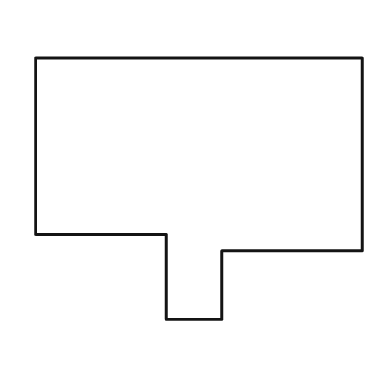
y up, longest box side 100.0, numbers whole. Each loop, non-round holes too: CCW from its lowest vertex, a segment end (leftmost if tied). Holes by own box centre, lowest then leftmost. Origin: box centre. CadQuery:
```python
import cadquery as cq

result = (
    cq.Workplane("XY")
    .moveTo(-10.0, -40.0)
    .lineTo(7.0, -40.0)
    .lineTo(7.0, -19.0)
    .lineTo(50.0, -19.0)
    .lineTo(50.0, 40.0)
    .lineTo(-50.0, 40.0)
    .lineTo(-50.0, -14.0)
    .lineTo(-10.0, -14.0)
    .close()
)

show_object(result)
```